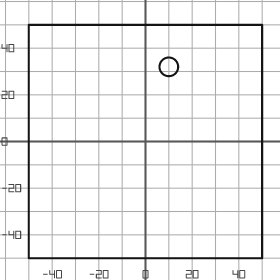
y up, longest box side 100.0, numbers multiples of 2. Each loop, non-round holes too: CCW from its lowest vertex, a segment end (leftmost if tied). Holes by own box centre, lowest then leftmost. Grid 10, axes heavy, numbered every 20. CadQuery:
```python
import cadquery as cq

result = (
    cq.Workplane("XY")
    .moveTo(-50.0, -50.0)
    .lineTo(50.0, -50.0)
    .lineTo(50.0, 50.0)
    .lineTo(-50.0, 50.0)
    .close()
    .moveTo(10.0, 32.0)
    .circle(4.0)
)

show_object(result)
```